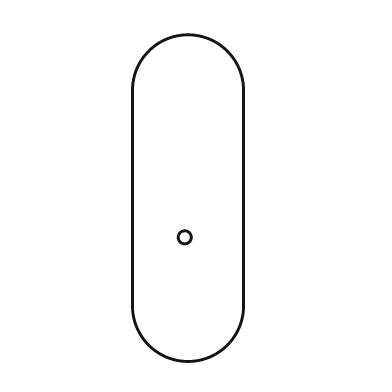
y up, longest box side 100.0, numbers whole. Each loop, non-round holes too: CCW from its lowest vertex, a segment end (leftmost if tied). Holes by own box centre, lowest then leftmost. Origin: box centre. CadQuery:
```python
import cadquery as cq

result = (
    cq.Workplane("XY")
    .moveTo(-17.0, -33.0)
    .threePointArc((0.0, -50.0), (17.0, -33.0))
    .lineTo(17.0, 33.0)
    .threePointArc((0.0, 50.0), (-17.0, 33.0))
    .close()
    .moveTo(-1.0, -12.0)
    .circle(2.0)
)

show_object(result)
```